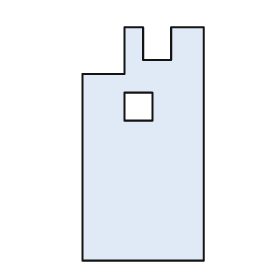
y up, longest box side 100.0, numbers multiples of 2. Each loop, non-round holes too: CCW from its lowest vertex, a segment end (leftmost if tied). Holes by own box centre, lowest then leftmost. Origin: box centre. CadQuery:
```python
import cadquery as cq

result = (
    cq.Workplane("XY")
    .moveTo(-26.0, -50.0)
    .lineTo(26.0, -50.0)
    .lineTo(26.0, 50.0)
    .lineTo(12.0, 50.0)
    .lineTo(12.0, 36.0)
    .lineTo(0.0, 36.0)
    .lineTo(0.0, 50.0)
    .lineTo(-8.0, 50.0)
    .lineTo(-8.0, 30.0)
    .lineTo(-26.0, 30.0)
    .close()
    .moveTo(-8.0, 10.0)
    .lineTo(4.0, 10.0)
    .lineTo(4.0, 22.0)
    .lineTo(-8.0, 22.0)
    .close()
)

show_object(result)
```